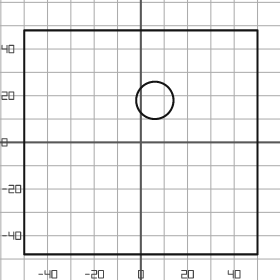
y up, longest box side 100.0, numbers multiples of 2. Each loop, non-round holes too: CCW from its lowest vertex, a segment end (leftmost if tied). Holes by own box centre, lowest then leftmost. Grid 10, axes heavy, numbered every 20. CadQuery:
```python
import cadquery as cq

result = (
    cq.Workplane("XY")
    .moveTo(-50.0, -48.0)
    .lineTo(50.0, -48.0)
    .lineTo(50.0, 48.0)
    .lineTo(-50.0, 48.0)
    .close()
    .moveTo(6.0, 18.0)
    .circle(8.0)
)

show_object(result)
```